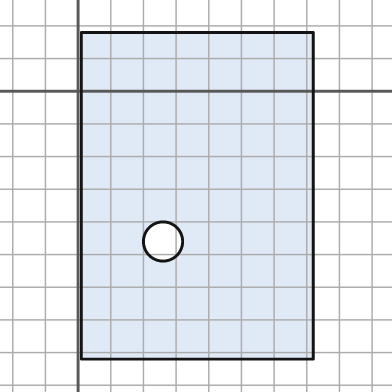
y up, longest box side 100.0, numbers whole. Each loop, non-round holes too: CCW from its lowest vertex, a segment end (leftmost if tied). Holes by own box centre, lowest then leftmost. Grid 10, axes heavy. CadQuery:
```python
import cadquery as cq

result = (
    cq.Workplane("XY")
    .moveTo(1.0, -82.0)
    .lineTo(72.0, -82.0)
    .lineTo(72.0, 18.0)
    .lineTo(1.0, 18.0)
    .close()
    .moveTo(26.0, -46.0)
    .circle(6.0)
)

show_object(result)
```